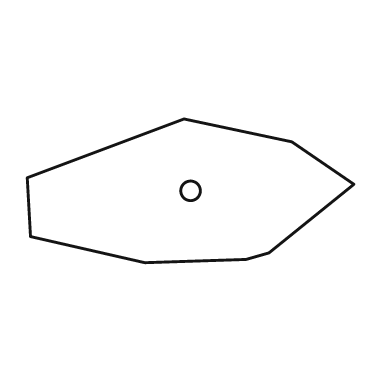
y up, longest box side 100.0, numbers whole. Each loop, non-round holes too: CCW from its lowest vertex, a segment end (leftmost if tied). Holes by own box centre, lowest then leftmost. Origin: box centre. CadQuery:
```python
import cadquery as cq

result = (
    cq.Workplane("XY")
    .moveTo(-14.0, -22.0)
    .lineTo(17.0, -21.0)
    .lineTo(24.0, -19.0)
    .lineTo(50.0, 2.0)
    .lineTo(31.0, 15.0)
    .lineTo(-2.0, 22.0)
    .lineTo(-50.0, 4.0)
    .lineTo(-49.0, -14.0)
    .close()
    .moveTo(0.0, 0.0)
    .circle(3.0)
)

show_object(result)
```